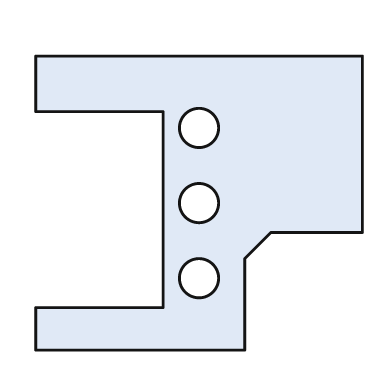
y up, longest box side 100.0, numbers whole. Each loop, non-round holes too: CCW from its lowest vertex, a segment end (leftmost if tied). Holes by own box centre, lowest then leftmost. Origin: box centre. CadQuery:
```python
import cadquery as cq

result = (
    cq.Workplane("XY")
    .moveTo(-50.0, -45.0)
    .lineTo(14.0, -45.0)
    .lineTo(14.0, -17.0)
    .lineTo(22.0, -9.0)
    .lineTo(50.0, -9.0)
    .lineTo(50.0, 45.0)
    .lineTo(-50.0, 45.0)
    .lineTo(-50.0, 28.0)
    .lineTo(-11.0, 28.0)
    .lineTo(-11.0, -32.0)
    .lineTo(-50.0, -32.0)
    .close()
    .moveTo(0.0, -23.0)
    .circle(6.0)
    .moveTo(0.0, 0.0)
    .circle(6.0)
    .moveTo(0.0, 23.0)
    .circle(6.0)
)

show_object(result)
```